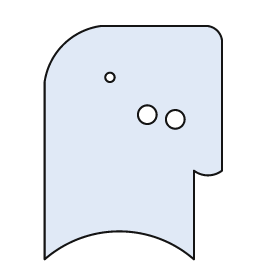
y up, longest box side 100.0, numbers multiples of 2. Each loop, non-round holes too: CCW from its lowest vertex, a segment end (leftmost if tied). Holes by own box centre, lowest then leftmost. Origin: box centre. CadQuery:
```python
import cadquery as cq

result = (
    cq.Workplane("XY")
    .moveTo(-38.0, -50.0)
    .threePointArc((-6.0, -38.0), (26.0, -50.0))
    .lineTo(26.0, -12.0)
    .threePointArc((32.0, -14.0), (38.0, -12.0))
    .lineTo(38.0, 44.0)
    .threePointArc((36.0, 48.0), (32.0, 50.0))
    .lineTo(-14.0, 50.0)
    .threePointArc((-30.0, 42.0), (-38.0, 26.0))
    .close()
    .moveTo(18.0, 10.0)
    .circle(4.0)
    .moveTo(6.0, 12.0)
    .circle(4.0)
    .moveTo(-10.0, 28.0)
    .circle(2.0)
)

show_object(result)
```